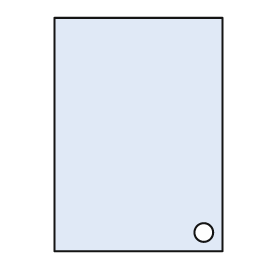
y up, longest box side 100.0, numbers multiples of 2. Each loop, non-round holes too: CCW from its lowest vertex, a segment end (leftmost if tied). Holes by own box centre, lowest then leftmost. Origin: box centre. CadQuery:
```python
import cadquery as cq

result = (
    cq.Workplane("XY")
    .moveTo(-36.0, -50.0)
    .lineTo(36.0, -50.0)
    .lineTo(36.0, 50.0)
    .lineTo(-36.0, 50.0)
    .close()
    .moveTo(28.0, -42.0)
    .circle(4.0)
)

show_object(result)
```